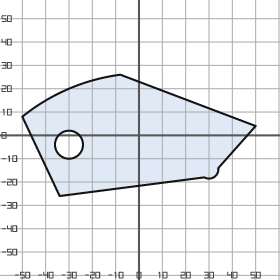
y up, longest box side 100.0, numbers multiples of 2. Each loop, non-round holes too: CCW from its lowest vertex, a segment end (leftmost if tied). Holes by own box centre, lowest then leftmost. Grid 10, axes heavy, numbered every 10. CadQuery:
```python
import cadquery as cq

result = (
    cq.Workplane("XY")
    .moveTo(-34.0, -26.0)
    .lineTo(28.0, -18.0)
    .threePointArc((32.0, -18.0), (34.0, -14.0))
    .lineTo(50.0, 4.0)
    .lineTo(-8.0, 26.0)
    .threePointArc((-30.0, 20.0), (-50.0, 8.0))
    .close()
    .moveTo(-30.0, -4.0)
    .circle(6.0)
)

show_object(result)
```